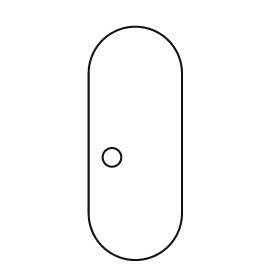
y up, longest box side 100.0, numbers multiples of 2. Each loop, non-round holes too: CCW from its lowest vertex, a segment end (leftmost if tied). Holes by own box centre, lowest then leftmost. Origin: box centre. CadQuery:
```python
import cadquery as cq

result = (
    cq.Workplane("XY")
    .moveTo(-20.0, -30.0)
    .threePointArc((0.0, -50.0), (20.0, -30.0))
    .lineTo(20.0, 30.0)
    .threePointArc((0.0, 50.0), (-20.0, 30.0))
    .close()
    .moveTo(-10.0, -6.0)
    .circle(4.0)
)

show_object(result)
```